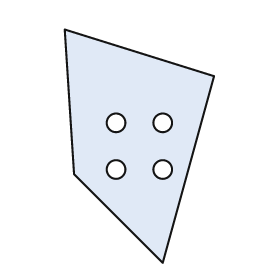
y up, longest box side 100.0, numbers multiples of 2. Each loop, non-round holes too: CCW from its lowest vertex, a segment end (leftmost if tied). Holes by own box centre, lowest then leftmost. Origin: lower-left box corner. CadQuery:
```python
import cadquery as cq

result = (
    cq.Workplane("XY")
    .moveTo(42.0, 0.0)
    .lineTo(64.0, 80.0)
    .lineTo(0.0, 100.0)
    .lineTo(4.0, 38.0)
    .close()
    .moveTo(22.0, 40.0)
    .circle(4.0)
    .moveTo(42.0, 40.0)
    .circle(4.0)
    .moveTo(22.0, 60.0)
    .circle(4.0)
    .moveTo(42.0, 60.0)
    .circle(4.0)
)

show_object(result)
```